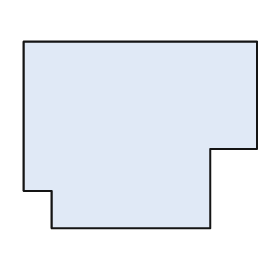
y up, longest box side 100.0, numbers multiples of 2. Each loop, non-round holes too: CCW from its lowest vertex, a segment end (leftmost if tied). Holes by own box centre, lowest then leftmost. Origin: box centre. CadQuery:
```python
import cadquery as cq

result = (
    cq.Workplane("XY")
    .moveTo(-38.0, -40.0)
    .lineTo(30.0, -40.0)
    .lineTo(30.0, -6.0)
    .lineTo(50.0, -6.0)
    .lineTo(50.0, 40.0)
    .lineTo(-50.0, 40.0)
    .lineTo(-50.0, -24.0)
    .lineTo(-38.0, -24.0)
    .close()
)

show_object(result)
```